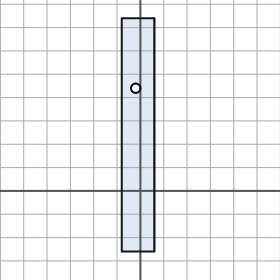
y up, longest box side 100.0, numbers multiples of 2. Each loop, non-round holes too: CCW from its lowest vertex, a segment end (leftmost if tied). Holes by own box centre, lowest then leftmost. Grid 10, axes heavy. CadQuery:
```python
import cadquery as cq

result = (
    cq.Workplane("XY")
    .moveTo(-8.0, -26.0)
    .lineTo(6.0, -26.0)
    .lineTo(6.0, 74.0)
    .lineTo(-8.0, 74.0)
    .close()
    .moveTo(-2.0, 44.0)
    .circle(2.0)
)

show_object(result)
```